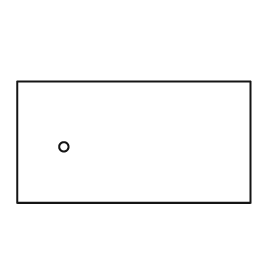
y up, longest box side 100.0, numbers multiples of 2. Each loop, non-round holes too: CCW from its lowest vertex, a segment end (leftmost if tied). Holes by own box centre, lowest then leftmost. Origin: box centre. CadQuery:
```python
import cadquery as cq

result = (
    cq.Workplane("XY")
    .moveTo(-50.0, -26.0)
    .lineTo(50.0, -26.0)
    .lineTo(50.0, 26.0)
    .lineTo(-50.0, 26.0)
    .close()
    .moveTo(-30.0, -2.0)
    .circle(2.0)
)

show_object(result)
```